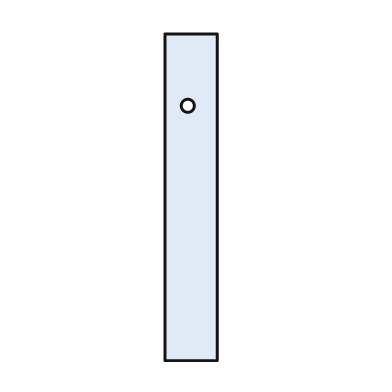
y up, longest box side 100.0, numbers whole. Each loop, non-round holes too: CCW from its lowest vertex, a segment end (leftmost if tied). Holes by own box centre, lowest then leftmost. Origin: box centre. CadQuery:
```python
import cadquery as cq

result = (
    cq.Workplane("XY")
    .moveTo(-8.0, -50.0)
    .lineTo(8.0, -50.0)
    .lineTo(8.0, 50.0)
    .lineTo(-8.0, 50.0)
    .close()
    .moveTo(-1.0, 28.0)
    .circle(2.0)
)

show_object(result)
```